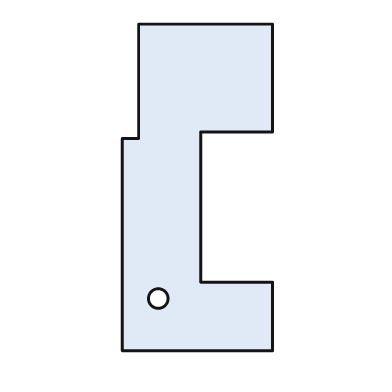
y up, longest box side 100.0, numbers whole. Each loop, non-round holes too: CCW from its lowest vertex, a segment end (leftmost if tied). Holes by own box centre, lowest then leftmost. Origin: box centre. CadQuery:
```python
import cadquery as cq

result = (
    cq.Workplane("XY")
    .moveTo(-23.0, -50.0)
    .lineTo(23.0, -50.0)
    .lineTo(23.0, -29.0)
    .lineTo(1.0, -29.0)
    .lineTo(1.0, 17.0)
    .lineTo(23.0, 17.0)
    .lineTo(23.0, 50.0)
    .lineTo(-18.0, 50.0)
    .lineTo(-18.0, 15.0)
    .lineTo(-23.0, 15.0)
    .close()
    .moveTo(-12.0, -34.0)
    .circle(3.0)
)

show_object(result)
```